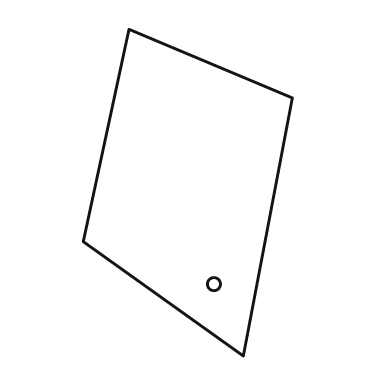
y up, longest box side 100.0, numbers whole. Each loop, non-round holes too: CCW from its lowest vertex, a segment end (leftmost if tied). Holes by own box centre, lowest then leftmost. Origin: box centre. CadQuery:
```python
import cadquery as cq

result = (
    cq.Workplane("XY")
    .moveTo(17.0, -50.0)
    .lineTo(32.0, 29.0)
    .lineTo(-18.0, 50.0)
    .lineTo(-32.0, -15.0)
    .close()
    .moveTo(8.0, -28.0)
    .circle(2.0)
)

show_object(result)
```